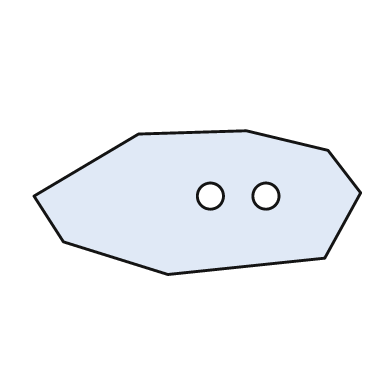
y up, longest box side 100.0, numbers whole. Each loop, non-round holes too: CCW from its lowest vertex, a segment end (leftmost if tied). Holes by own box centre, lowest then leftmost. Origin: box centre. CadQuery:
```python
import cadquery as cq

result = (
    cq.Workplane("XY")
    .moveTo(-9.0, -22.0)
    .lineTo(39.0, -17.0)
    .lineTo(50.0, 3.0)
    .lineTo(40.0, 16.0)
    .lineTo(15.0, 22.0)
    .lineTo(-18.0, 21.0)
    .lineTo(-50.0, 2.0)
    .lineTo(-41.0, -12.0)
    .close()
    .moveTo(4.0, 2.0)
    .circle(4.0)
    .moveTo(21.0, 2.0)
    .circle(4.0)
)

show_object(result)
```